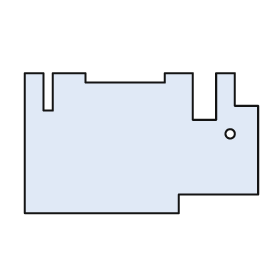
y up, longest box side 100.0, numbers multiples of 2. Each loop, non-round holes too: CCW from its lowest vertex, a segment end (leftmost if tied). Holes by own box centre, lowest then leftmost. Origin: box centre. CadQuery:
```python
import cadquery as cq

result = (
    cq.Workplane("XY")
    .moveTo(-50.0, -30.0)
    .lineTo(16.0, -30.0)
    .lineTo(16.0, -22.0)
    .lineTo(50.0, -22.0)
    .lineTo(50.0, 16.0)
    .lineTo(40.0, 16.0)
    .lineTo(40.0, 30.0)
    .lineTo(32.0, 30.0)
    .lineTo(32.0, 10.0)
    .lineTo(22.0, 10.0)
    .lineTo(22.0, 30.0)
    .lineTo(10.0, 30.0)
    .lineTo(10.0, 26.0)
    .lineTo(-24.0, 26.0)
    .lineTo(-24.0, 30.0)
    .lineTo(-38.0, 30.0)
    .lineTo(-38.0, 14.0)
    .lineTo(-42.0, 14.0)
    .lineTo(-42.0, 30.0)
    .lineTo(-50.0, 30.0)
    .close()
    .moveTo(38.0, 4.0)
    .circle(2.0)
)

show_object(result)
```